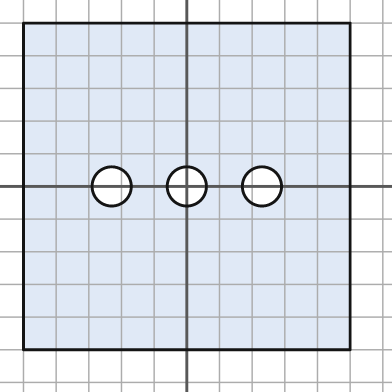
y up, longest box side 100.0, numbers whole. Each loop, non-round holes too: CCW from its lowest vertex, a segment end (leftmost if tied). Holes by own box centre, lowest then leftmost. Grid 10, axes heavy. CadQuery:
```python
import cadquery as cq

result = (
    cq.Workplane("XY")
    .moveTo(-50.0, -50.0)
    .lineTo(50.0, -50.0)
    .lineTo(50.0, 50.0)
    .lineTo(-50.0, 50.0)
    .close()
    .moveTo(-23.0, 0.0)
    .circle(6.0)
    .moveTo(0.0, 0.0)
    .circle(6.0)
    .moveTo(23.0, 0.0)
    .circle(6.0)
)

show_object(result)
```